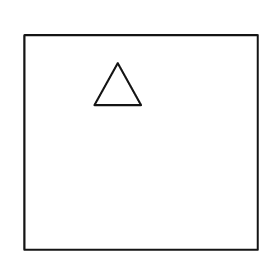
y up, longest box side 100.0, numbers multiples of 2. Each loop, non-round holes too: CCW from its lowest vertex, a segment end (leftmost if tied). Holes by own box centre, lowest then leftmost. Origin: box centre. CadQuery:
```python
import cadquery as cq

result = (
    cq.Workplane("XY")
    .moveTo(-50.0, -46.0)
    .lineTo(50.0, -46.0)
    .lineTo(50.0, 46.0)
    .lineTo(-50.0, 46.0)
    .close()
    .moveTo(-20.0, 16.0)
    .lineTo(0.0, 16.0)
    .lineTo(-10.0, 34.0)
    .close()
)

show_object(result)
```